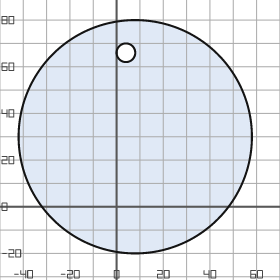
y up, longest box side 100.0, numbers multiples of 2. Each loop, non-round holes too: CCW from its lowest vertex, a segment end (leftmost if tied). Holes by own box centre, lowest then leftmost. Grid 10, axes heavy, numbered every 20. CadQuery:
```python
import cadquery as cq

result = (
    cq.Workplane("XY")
    .moveTo(8.0, 30.0)
    .circle(50.0)
    .moveTo(4.0, 66.0)
    .circle(4.0)
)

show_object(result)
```